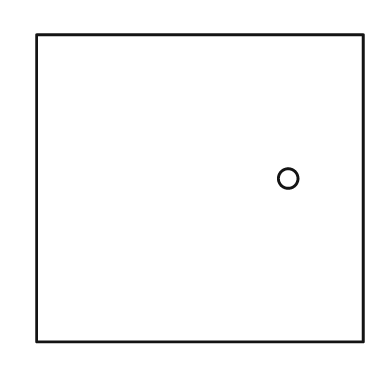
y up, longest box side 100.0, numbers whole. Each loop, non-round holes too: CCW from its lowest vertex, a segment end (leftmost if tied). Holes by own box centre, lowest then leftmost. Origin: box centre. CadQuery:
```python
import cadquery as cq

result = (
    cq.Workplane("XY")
    .moveTo(-50.0, -47.0)
    .lineTo(50.0, -47.0)
    .lineTo(50.0, 47.0)
    .lineTo(-50.0, 47.0)
    .close()
    .moveTo(27.0, 3.0)
    .circle(3.0)
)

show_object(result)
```